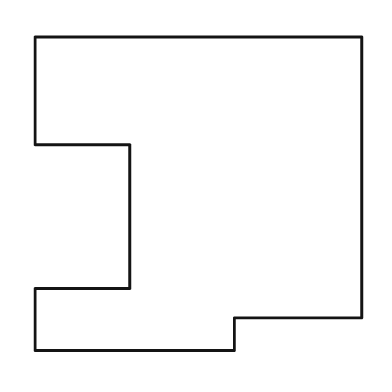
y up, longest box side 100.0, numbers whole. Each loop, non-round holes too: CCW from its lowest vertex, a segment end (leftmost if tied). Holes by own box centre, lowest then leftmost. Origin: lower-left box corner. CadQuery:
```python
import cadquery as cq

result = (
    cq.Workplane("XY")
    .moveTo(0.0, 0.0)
    .lineTo(61.0, 0.0)
    .lineTo(61.0, 10.0)
    .lineTo(100.0, 10.0)
    .lineTo(100.0, 96.0)
    .lineTo(0.0, 96.0)
    .lineTo(0.0, 63.0)
    .lineTo(29.0, 63.0)
    .lineTo(29.0, 19.0)
    .lineTo(0.0, 19.0)
    .close()
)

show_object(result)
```